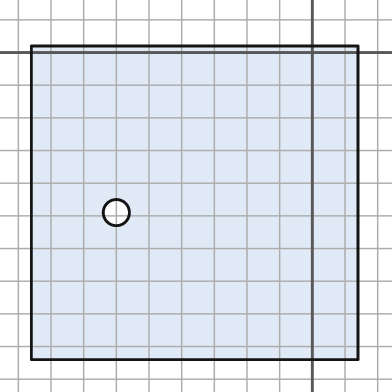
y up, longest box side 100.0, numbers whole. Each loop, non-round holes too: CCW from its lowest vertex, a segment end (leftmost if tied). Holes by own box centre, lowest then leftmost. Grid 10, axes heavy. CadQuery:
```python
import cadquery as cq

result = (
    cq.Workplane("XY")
    .moveTo(-86.0, -94.0)
    .lineTo(14.0, -94.0)
    .lineTo(14.0, 2.0)
    .lineTo(-86.0, 2.0)
    .close()
    .moveTo(-60.0, -49.0)
    .circle(4.0)
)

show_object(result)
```